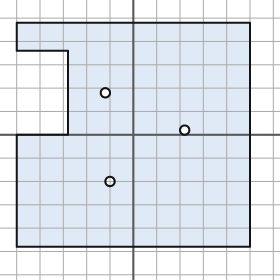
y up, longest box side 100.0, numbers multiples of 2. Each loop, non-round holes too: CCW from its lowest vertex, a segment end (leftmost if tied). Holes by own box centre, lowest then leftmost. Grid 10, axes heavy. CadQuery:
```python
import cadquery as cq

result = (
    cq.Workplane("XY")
    .moveTo(-50.0, -48.0)
    .lineTo(50.0, -48.0)
    .lineTo(50.0, 48.0)
    .lineTo(-50.0, 48.0)
    .lineTo(-50.0, 36.0)
    .lineTo(-28.0, 36.0)
    .lineTo(-28.0, 0.0)
    .lineTo(-50.0, 0.0)
    .close()
    .moveTo(-10.0, -20.0)
    .circle(2.0)
    .moveTo(22.0, 2.0)
    .circle(2.0)
    .moveTo(-12.0, 18.0)
    .circle(2.0)
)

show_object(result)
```